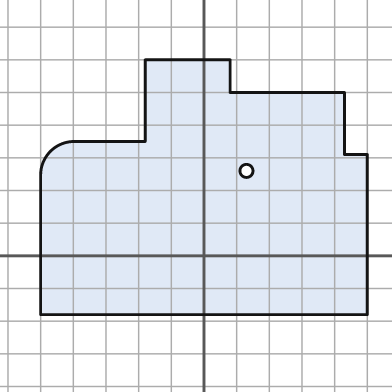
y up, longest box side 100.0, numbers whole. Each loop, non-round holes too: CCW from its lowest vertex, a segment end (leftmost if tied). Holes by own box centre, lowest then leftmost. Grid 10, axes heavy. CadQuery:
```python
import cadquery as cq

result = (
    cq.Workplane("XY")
    .moveTo(-50.0, -18.0)
    .lineTo(50.0, -18.0)
    .lineTo(50.0, 31.0)
    .lineTo(43.0, 31.0)
    .lineTo(43.0, 50.0)
    .lineTo(8.0, 50.0)
    .lineTo(8.0, 60.0)
    .lineTo(-18.0, 60.0)
    .lineTo(-18.0, 35.0)
    .lineTo(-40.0, 35.0)
    .threePointArc((-47.0, 32.0), (-50.0, 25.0))
    .close()
    .moveTo(13.0, 26.0)
    .circle(2.0)
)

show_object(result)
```